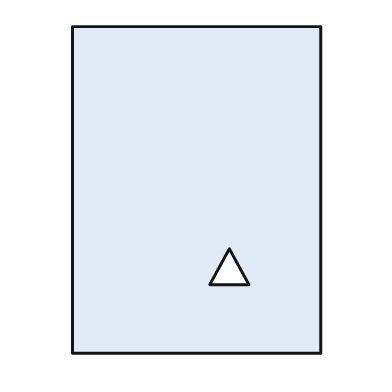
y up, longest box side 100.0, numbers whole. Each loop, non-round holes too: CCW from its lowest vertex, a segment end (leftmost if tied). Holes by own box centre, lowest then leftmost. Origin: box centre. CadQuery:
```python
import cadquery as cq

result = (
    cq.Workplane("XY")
    .moveTo(-38.0, -50.0)
    .lineTo(38.0, -50.0)
    .lineTo(38.0, 50.0)
    .lineTo(-38.0, 50.0)
    .close()
    .moveTo(4.0, -29.0)
    .lineTo(16.0, -29.0)
    .lineTo(10.0, -18.0)
    .close()
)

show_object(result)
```